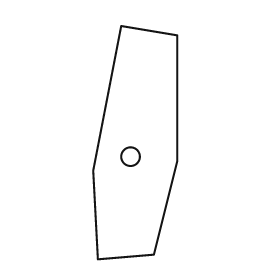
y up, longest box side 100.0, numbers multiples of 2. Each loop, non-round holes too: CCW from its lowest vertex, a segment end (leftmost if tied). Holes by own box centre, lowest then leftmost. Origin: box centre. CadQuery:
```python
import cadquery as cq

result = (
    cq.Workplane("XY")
    .moveTo(-16.0, -50.0)
    .lineTo(8.0, -48.0)
    .lineTo(18.0, -8.0)
    .lineTo(18.0, 46.0)
    .lineTo(-6.0, 50.0)
    .lineTo(-18.0, -12.0)
    .close()
    .moveTo(-2.0, -6.0)
    .circle(4.0)
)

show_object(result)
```